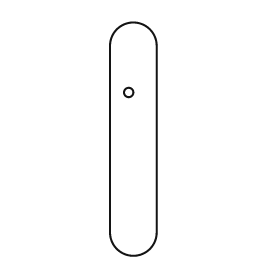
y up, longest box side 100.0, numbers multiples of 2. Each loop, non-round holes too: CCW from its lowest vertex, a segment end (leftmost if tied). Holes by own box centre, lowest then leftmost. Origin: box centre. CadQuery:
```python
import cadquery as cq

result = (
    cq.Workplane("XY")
    .moveTo(-10.0, -40.0)
    .threePointArc((0.0, -50.0), (10.0, -40.0))
    .lineTo(10.0, 40.0)
    .threePointArc((0.0, 50.0), (-10.0, 40.0))
    .close()
    .moveTo(-2.0, 20.0)
    .circle(2.0)
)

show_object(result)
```